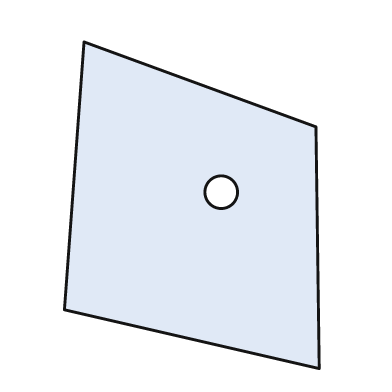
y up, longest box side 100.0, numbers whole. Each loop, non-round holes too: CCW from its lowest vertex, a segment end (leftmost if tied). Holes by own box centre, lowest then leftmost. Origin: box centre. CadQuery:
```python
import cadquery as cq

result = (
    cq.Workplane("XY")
    .moveTo(39.0, -50.0)
    .lineTo(38.0, 24.0)
    .lineTo(-33.0, 50.0)
    .lineTo(-39.0, -32.0)
    .close()
    .moveTo(9.0, 4.0)
    .circle(5.0)
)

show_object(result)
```